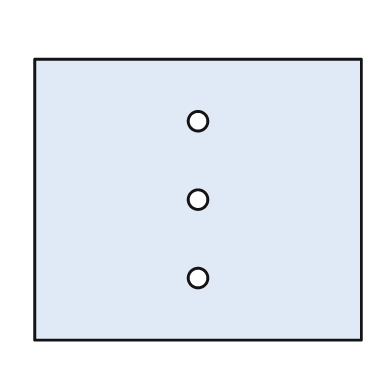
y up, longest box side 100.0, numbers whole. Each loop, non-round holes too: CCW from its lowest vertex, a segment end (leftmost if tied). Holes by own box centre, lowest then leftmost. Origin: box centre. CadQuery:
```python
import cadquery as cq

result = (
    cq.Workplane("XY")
    .moveTo(-50.0, -43.0)
    .lineTo(50.0, -43.0)
    .lineTo(50.0, 43.0)
    .lineTo(-50.0, 43.0)
    .close()
    .moveTo(0.0, -24.0)
    .circle(3.0)
    .moveTo(0.0, 0.0)
    .circle(3.0)
    .moveTo(0.0, 24.0)
    .circle(3.0)
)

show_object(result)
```